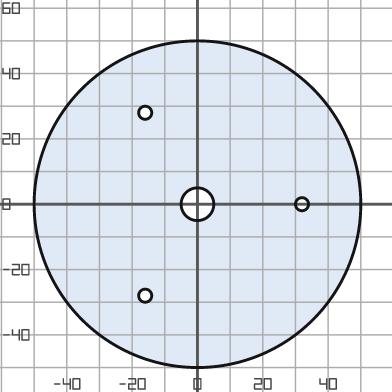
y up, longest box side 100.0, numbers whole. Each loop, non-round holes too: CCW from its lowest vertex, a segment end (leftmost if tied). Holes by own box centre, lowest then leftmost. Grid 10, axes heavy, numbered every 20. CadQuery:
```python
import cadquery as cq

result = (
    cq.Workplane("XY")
    .moveTo(0.0, 0.0)
    .circle(50.0)
    .moveTo(-16.0, -28.0)
    .circle(2.0)
    .moveTo(0.0, 0.0)
    .circle(5.0)
    .moveTo(32.0, 0.0)
    .circle(2.0)
    .moveTo(-16.0, 28.0)
    .circle(2.0)
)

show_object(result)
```